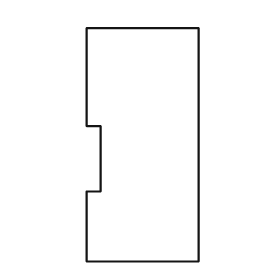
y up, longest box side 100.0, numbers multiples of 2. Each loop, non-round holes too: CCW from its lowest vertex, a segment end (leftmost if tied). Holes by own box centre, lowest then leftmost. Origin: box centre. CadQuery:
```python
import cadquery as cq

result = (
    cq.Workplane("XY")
    .moveTo(-24.0, -50.0)
    .lineTo(24.0, -50.0)
    .lineTo(24.0, 50.0)
    .lineTo(-24.0, 50.0)
    .lineTo(-24.0, 8.0)
    .lineTo(-18.0, 8.0)
    .lineTo(-18.0, -20.0)
    .lineTo(-24.0, -20.0)
    .close()
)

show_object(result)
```